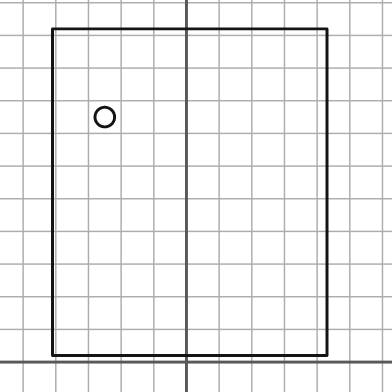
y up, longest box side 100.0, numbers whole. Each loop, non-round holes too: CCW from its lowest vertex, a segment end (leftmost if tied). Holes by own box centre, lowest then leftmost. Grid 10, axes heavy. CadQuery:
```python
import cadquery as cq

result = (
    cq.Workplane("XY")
    .moveTo(-41.0, 2.0)
    .lineTo(43.0, 2.0)
    .lineTo(43.0, 102.0)
    .lineTo(-41.0, 102.0)
    .close()
    .moveTo(-25.0, 75.0)
    .circle(3.0)
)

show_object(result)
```